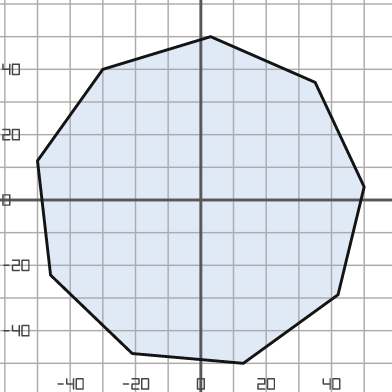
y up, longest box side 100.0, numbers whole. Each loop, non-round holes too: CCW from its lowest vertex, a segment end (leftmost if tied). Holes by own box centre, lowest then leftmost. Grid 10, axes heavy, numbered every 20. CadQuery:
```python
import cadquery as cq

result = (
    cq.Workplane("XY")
    .moveTo(13.0, -50.0)
    .lineTo(42.0, -29.0)
    .lineTo(50.0, 4.0)
    .lineTo(35.0, 36.0)
    .lineTo(3.0, 50.0)
    .lineTo(-30.0, 40.0)
    .lineTo(-50.0, 12.0)
    .lineTo(-46.0, -23.0)
    .lineTo(-21.0, -47.0)
    .close()
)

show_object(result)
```